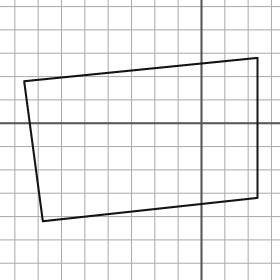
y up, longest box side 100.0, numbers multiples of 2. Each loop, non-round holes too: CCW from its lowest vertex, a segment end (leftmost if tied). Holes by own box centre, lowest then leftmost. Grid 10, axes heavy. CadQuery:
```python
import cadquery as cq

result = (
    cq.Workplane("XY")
    .moveTo(-68.0, -42.0)
    .lineTo(24.0, -32.0)
    .lineTo(24.0, 28.0)
    .lineTo(-76.0, 18.0)
    .close()
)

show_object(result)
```